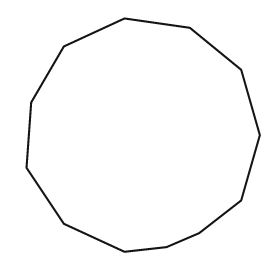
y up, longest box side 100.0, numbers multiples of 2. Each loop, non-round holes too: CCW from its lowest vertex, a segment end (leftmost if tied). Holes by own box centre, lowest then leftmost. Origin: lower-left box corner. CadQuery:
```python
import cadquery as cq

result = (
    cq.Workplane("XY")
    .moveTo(42.0, 0.0)
    .lineTo(60.0, 2.0)
    .lineTo(74.0, 8.0)
    .lineTo(92.0, 22.0)
    .lineTo(100.0, 50.0)
    .lineTo(92.0, 78.0)
    .lineTo(70.0, 96.0)
    .lineTo(42.0, 100.0)
    .lineTo(16.0, 88.0)
    .lineTo(2.0, 64.0)
    .lineTo(0.0, 36.0)
    .lineTo(16.0, 12.0)
    .close()
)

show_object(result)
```